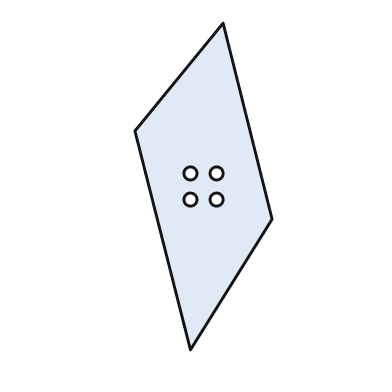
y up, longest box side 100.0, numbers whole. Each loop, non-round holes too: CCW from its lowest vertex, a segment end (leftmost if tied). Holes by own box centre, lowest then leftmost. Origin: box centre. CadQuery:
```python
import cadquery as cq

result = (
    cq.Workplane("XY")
    .moveTo(-4.0, -50.0)
    .lineTo(21.0, -10.0)
    .lineTo(6.0, 50.0)
    .lineTo(-21.0, 17.0)
    .close()
    .moveTo(-4.0, -4.0)
    .circle(2.0)
    .moveTo(4.0, -4.0)
    .circle(2.0)
    .moveTo(-4.0, 4.0)
    .circle(2.0)
    .moveTo(4.0, 4.0)
    .circle(2.0)
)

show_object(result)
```